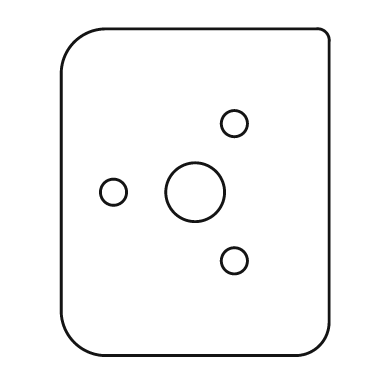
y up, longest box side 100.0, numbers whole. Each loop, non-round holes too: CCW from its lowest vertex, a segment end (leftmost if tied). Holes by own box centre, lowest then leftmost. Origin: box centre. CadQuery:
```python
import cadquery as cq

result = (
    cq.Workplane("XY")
    .moveTo(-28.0, -50.0)
    .lineTo(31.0, -50.0)
    .threePointArc((38.0, -47.0), (41.0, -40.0))
    .lineTo(41.0, 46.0)
    .threePointArc((40.0, 49.0), (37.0, 50.0))
    .lineTo(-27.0, 50.0)
    .threePointArc((-37.0, 46.0), (-41.0, 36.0))
    .lineTo(-41.0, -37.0)
    .threePointArc((-37.0, -46.0), (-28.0, -50.0))
    .close()
    .moveTo(12.0, -21.0)
    .circle(4.0)
    .moveTo(-25.0, 0.0)
    .circle(4.0)
    .moveTo(0.0, 0.0)
    .circle(9.0)
    .moveTo(12.0, 21.0)
    .circle(4.0)
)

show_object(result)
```